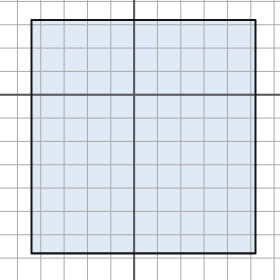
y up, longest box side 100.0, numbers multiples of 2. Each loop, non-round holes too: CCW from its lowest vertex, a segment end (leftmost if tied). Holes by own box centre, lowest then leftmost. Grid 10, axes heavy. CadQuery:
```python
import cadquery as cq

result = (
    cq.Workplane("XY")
    .moveTo(-44.0, -68.0)
    .lineTo(52.0, -68.0)
    .lineTo(52.0, 32.0)
    .lineTo(-44.0, 32.0)
    .close()
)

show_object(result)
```